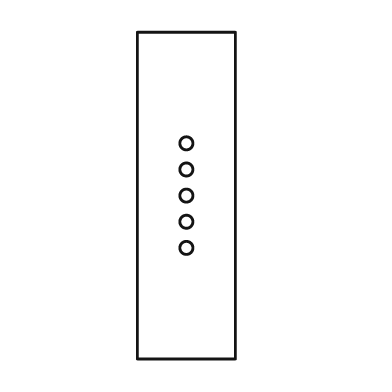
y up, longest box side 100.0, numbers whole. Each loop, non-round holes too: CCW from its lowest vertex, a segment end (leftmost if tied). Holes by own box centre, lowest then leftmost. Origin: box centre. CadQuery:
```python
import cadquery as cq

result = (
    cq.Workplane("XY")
    .moveTo(-15.0, -50.0)
    .lineTo(15.0, -50.0)
    .lineTo(15.0, 50.0)
    .lineTo(-15.0, 50.0)
    .close()
    .moveTo(0.0, -16.0)
    .circle(2.0)
    .moveTo(0.0, -8.0)
    .circle(2.0)
    .moveTo(0.0, 0.0)
    .circle(2.0)
    .moveTo(0.0, 8.0)
    .circle(2.0)
    .moveTo(0.0, 16.0)
    .circle(2.0)
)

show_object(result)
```